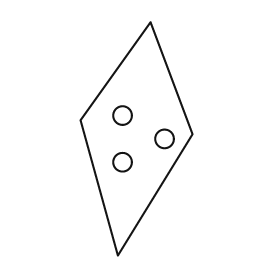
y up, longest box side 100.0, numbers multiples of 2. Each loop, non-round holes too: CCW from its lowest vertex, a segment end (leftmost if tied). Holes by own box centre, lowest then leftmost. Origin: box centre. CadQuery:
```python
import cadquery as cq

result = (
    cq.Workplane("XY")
    .moveTo(-8.0, -50.0)
    .lineTo(24.0, 2.0)
    .lineTo(6.0, 50.0)
    .lineTo(-24.0, 8.0)
    .close()
    .moveTo(-6.0, -10.0)
    .circle(4.0)
    .moveTo(12.0, 0.0)
    .circle(4.0)
    .moveTo(-6.0, 10.0)
    .circle(4.0)
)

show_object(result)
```